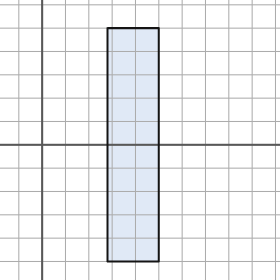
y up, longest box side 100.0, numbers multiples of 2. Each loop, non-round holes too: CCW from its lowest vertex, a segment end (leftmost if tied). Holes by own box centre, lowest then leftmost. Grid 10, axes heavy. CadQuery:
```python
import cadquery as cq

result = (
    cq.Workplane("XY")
    .moveTo(28.0, -50.0)
    .lineTo(50.0, -50.0)
    .lineTo(50.0, 50.0)
    .lineTo(28.0, 50.0)
    .close()
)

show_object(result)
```